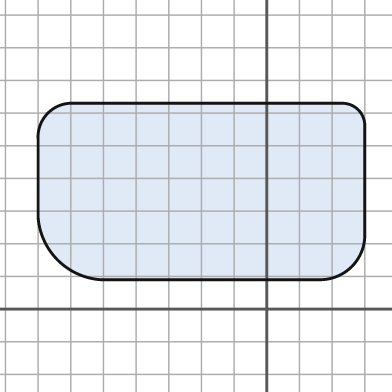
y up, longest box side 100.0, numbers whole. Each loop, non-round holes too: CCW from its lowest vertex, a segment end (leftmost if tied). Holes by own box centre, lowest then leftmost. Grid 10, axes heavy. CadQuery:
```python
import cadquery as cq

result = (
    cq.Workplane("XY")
    .moveTo(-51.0, 9.0)
    .lineTo(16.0, 9.0)
    .threePointArc((26.0, 13.0), (30.0, 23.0))
    .lineTo(30.0, 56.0)
    .threePointArc((28.0, 61.0), (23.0, 63.0))
    .lineTo(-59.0, 63.0)
    .threePointArc((-67.0, 60.0), (-70.0, 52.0))
    .lineTo(-70.0, 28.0)
    .threePointArc((-64.0, 15.0), (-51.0, 9.0))
    .close()
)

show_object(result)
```